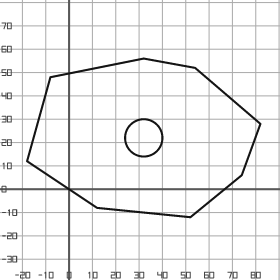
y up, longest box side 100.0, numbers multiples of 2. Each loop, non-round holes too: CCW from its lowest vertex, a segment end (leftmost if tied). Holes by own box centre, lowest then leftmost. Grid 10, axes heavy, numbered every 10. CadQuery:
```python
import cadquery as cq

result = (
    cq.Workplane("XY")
    .moveTo(52.0, -12.0)
    .lineTo(74.0, 6.0)
    .lineTo(82.0, 28.0)
    .lineTo(54.0, 52.0)
    .lineTo(32.0, 56.0)
    .lineTo(-8.0, 48.0)
    .lineTo(-18.0, 12.0)
    .lineTo(12.0, -8.0)
    .close()
    .moveTo(32.0, 22.0)
    .circle(8.0)
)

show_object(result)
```